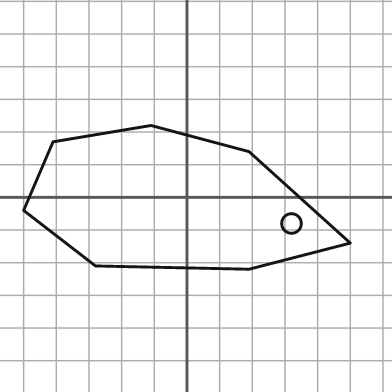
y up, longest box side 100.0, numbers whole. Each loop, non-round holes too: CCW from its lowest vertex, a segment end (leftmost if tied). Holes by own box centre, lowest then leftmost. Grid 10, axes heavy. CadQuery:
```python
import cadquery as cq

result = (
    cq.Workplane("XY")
    .moveTo(19.0, -22.0)
    .lineTo(50.0, -14.0)
    .lineTo(19.0, 14.0)
    .lineTo(-11.0, 22.0)
    .lineTo(-41.0, 17.0)
    .lineTo(-50.0, -4.0)
    .lineTo(-28.0, -21.0)
    .close()
    .moveTo(32.0, -8.0)
    .circle(3.0)
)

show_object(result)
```